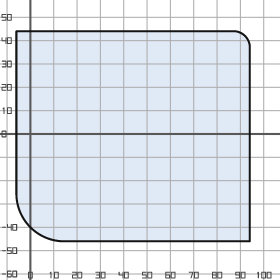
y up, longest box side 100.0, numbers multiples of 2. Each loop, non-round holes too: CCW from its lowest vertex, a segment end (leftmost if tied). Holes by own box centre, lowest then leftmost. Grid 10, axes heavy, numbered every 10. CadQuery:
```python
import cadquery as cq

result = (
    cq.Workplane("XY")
    .moveTo(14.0, -46.0)
    .lineTo(94.0, -46.0)
    .lineTo(94.0, 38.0)
    .threePointArc((92.0, 42.0), (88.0, 44.0))
    .lineTo(-6.0, 44.0)
    .lineTo(-6.0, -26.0)
    .threePointArc((0.0, -40.0), (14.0, -46.0))
    .close()
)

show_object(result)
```